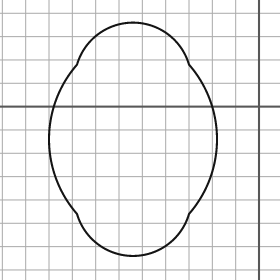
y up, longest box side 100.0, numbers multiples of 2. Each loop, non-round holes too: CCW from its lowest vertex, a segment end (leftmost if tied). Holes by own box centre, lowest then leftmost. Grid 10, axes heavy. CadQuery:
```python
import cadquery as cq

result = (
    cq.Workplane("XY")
    .moveTo(-78.0, -46.0)
    .threePointArc((-54.0, -64.0), (-30.0, -46.0))
    .threePointArc((-18.0, -14.0), (-30.0, 18.0))
    .threePointArc((-54.0, 36.0), (-78.0, 18.0))
    .threePointArc((-90.0, -14.0), (-78.0, -46.0))
    .close()
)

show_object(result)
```